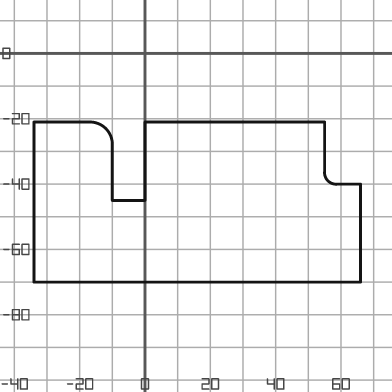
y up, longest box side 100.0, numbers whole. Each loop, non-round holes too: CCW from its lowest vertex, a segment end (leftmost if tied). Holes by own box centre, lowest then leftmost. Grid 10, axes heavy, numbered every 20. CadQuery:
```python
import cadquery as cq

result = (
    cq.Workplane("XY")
    .moveTo(-34.0, -70.0)
    .lineTo(66.0, -70.0)
    .lineTo(66.0, -40.0)
    .lineTo(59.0, -40.0)
    .threePointArc((56.0, -39.0), (55.0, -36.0))
    .lineTo(55.0, -21.0)
    .lineTo(0.0, -21.0)
    .lineTo(0.0, -45.0)
    .lineTo(-10.0, -45.0)
    .lineTo(-10.0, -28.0)
    .threePointArc((-12.0, -23.0), (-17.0, -21.0))
    .lineTo(-34.0, -21.0)
    .close()
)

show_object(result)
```